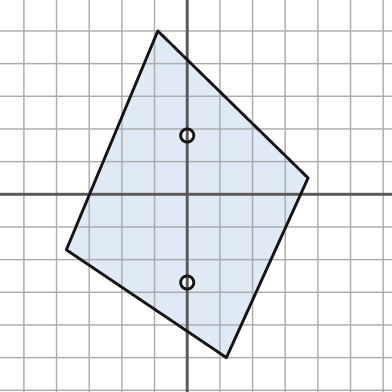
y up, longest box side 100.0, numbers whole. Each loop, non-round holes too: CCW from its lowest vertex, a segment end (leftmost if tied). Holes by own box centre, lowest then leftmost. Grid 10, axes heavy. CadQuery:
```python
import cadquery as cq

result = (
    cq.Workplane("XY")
    .moveTo(12.0, -50.0)
    .lineTo(37.0, 5.0)
    .lineTo(-9.0, 50.0)
    .lineTo(-37.0, -17.0)
    .close()
    .moveTo(0.0, -27.0)
    .circle(2.0)
    .moveTo(0.0, 18.0)
    .circle(2.0)
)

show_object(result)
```